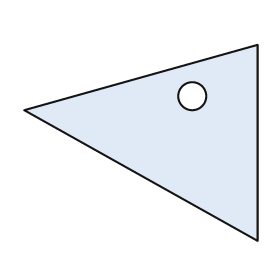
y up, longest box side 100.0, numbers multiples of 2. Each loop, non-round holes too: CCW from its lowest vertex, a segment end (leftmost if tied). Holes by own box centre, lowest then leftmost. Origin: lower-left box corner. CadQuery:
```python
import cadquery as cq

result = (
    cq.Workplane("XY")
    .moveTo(100.0, 0.0)
    .lineTo(100.0, 84.0)
    .lineTo(0.0, 56.0)
    .close()
    .moveTo(72.0, 62.0)
    .circle(6.0)
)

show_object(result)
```